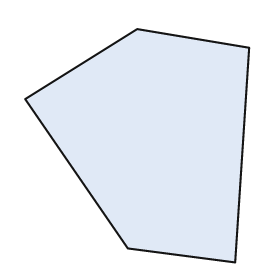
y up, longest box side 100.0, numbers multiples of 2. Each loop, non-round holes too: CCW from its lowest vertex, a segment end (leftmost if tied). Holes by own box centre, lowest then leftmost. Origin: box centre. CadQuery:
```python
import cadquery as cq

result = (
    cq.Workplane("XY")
    .moveTo(42.0, -50.0)
    .lineTo(48.0, 42.0)
    .lineTo(0.0, 50.0)
    .lineTo(-48.0, 20.0)
    .lineTo(-4.0, -44.0)
    .close()
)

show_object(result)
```